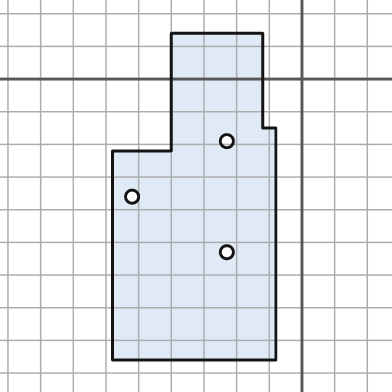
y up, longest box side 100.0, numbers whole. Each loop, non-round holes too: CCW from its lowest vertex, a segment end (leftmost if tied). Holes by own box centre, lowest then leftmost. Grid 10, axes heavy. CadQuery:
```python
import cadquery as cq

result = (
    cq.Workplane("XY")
    .moveTo(-58.0, -86.0)
    .lineTo(-8.0, -86.0)
    .lineTo(-8.0, -15.0)
    .lineTo(-12.0, -15.0)
    .lineTo(-12.0, 14.0)
    .lineTo(-40.0, 14.0)
    .lineTo(-40.0, -22.0)
    .lineTo(-58.0, -22.0)
    .close()
    .moveTo(-23.0, -53.0)
    .circle(2.0)
    .moveTo(-52.0, -36.0)
    .circle(2.0)
    .moveTo(-23.0, -19.0)
    .circle(2.0)
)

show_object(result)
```